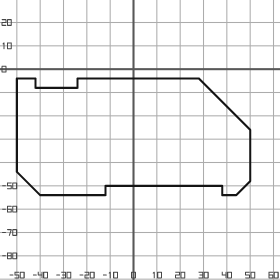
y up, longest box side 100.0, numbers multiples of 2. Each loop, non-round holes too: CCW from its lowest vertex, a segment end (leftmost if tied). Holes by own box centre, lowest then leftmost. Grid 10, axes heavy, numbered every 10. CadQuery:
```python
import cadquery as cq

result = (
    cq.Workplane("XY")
    .moveTo(-40.0, -54.0)
    .lineTo(-12.0, -54.0)
    .lineTo(-12.0, -50.0)
    .lineTo(38.0, -50.0)
    .lineTo(38.0, -54.0)
    .lineTo(44.0, -54.0)
    .lineTo(50.0, -48.0)
    .lineTo(50.0, -26.0)
    .lineTo(28.0, -4.0)
    .lineTo(-24.0, -4.0)
    .lineTo(-24.0, -8.0)
    .lineTo(-42.0, -8.0)
    .lineTo(-42.0, -4.0)
    .lineTo(-50.0, -4.0)
    .lineTo(-50.0, -44.0)
    .close()
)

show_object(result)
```